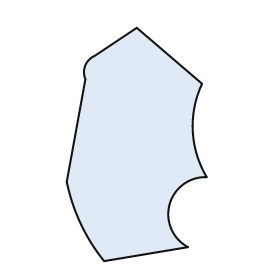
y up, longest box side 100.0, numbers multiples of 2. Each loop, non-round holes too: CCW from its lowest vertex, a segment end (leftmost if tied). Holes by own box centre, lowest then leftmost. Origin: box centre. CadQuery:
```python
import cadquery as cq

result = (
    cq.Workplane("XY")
    .moveTo(-14.0, -50.0)
    .lineTo(22.0, -44.0)
    .threePointArc((14.0, -26.0), (30.0, -14.0))
    .threePointArc((24.0, 6.0), (28.0, 26.0))
    .lineTo(0.0, 50.0)
    .lineTo(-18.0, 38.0)
    .threePointArc((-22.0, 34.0), (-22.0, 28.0))
    .lineTo(-30.0, -16.0)
    .threePointArc((-24.0, -34.0), (-14.0, -50.0))
    .close()
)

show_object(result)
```